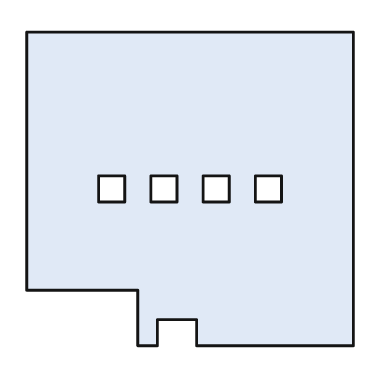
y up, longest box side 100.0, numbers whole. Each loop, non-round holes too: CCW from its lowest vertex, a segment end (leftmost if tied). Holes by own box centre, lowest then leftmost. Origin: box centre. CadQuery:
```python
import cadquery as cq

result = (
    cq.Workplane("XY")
    .moveTo(-16.0, -48.0)
    .lineTo(-10.0, -48.0)
    .lineTo(-10.0, -40.0)
    .lineTo(2.0, -40.0)
    .lineTo(2.0, -48.0)
    .lineTo(50.0, -48.0)
    .lineTo(50.0, 48.0)
    .lineTo(-50.0, 48.0)
    .lineTo(-50.0, -31.0)
    .lineTo(-16.0, -31.0)
    .close()
    .moveTo(-28.0, -4.0)
    .lineTo(-20.0, -4.0)
    .lineTo(-20.0, 4.0)
    .lineTo(-28.0, 4.0)
    .close()
    .moveTo(-12.0, -4.0)
    .lineTo(-4.0, -4.0)
    .lineTo(-4.0, 4.0)
    .lineTo(-12.0, 4.0)
    .close()
    .moveTo(4.0, -4.0)
    .lineTo(12.0, -4.0)
    .lineTo(12.0, 4.0)
    .lineTo(4.0, 4.0)
    .close()
    .moveTo(20.0, -4.0)
    .lineTo(28.0, -4.0)
    .lineTo(28.0, 4.0)
    .lineTo(20.0, 4.0)
    .close()
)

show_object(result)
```